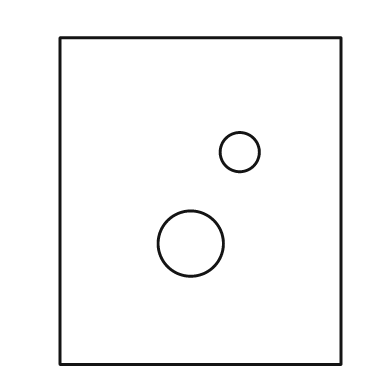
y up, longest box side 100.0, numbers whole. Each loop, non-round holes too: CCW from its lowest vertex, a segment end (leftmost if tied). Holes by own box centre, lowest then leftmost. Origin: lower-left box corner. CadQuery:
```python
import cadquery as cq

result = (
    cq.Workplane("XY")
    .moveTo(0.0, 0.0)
    .lineTo(86.0, 0.0)
    .lineTo(86.0, 100.0)
    .lineTo(0.0, 100.0)
    .close()
    .moveTo(40.0, 37.0)
    .circle(10.0)
    .moveTo(55.0, 65.0)
    .circle(6.0)
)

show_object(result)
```